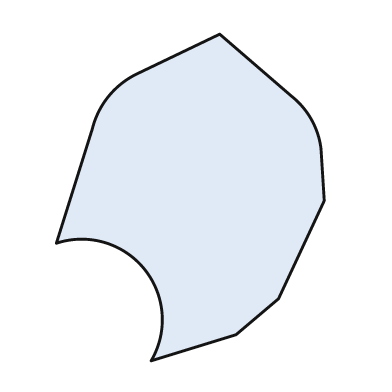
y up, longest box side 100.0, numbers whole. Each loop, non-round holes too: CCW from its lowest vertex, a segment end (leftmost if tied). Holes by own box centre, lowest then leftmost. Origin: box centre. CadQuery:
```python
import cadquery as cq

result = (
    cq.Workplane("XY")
    .moveTo(-12.0, -50.0)
    .lineTo(14.0, -42.0)
    .lineTo(27.0, -31.0)
    .lineTo(41.0, -1.0)
    .lineTo(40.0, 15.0)
    .threePointArc((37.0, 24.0), (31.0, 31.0))
    .lineTo(9.0, 50.0)
    .lineTo(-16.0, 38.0)
    .threePointArc((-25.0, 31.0), (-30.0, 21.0))
    .lineTo(-41.0, -14.0)
    .threePointArc((-14.0, -22.0), (-12.0, -50.0))
    .close()
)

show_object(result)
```